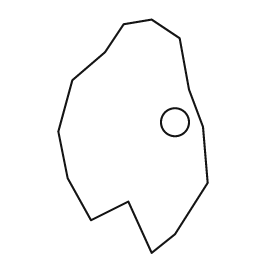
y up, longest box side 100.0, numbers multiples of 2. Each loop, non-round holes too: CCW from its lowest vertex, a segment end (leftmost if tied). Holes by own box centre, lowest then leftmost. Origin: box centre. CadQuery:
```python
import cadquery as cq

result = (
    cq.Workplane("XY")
    .moveTo(8.0, -50.0)
    .lineTo(18.0, -42.0)
    .lineTo(32.0, -20.0)
    .lineTo(30.0, 4.0)
    .lineTo(24.0, 20.0)
    .lineTo(20.0, 42.0)
    .lineTo(8.0, 50.0)
    .lineTo(-4.0, 48.0)
    .lineTo(-12.0, 36.0)
    .lineTo(-26.0, 24.0)
    .lineTo(-32.0, 2.0)
    .lineTo(-28.0, -18.0)
    .lineTo(-18.0, -36.0)
    .lineTo(-2.0, -28.0)
    .close()
    .moveTo(18.0, 6.0)
    .circle(6.0)
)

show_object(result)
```